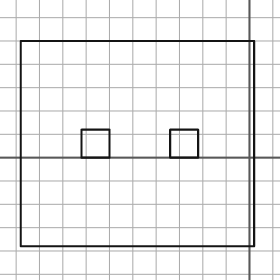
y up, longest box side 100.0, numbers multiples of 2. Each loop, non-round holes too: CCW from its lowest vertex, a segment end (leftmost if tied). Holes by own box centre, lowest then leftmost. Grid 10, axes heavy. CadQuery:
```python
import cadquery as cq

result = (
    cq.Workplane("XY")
    .moveTo(-98.0, -38.0)
    .lineTo(2.0, -38.0)
    .lineTo(2.0, 50.0)
    .lineTo(-98.0, 50.0)
    .close()
    .moveTo(-72.0, 0.0)
    .lineTo(-60.0, 0.0)
    .lineTo(-60.0, 12.0)
    .lineTo(-72.0, 12.0)
    .close()
    .moveTo(-34.0, 0.0)
    .lineTo(-22.0, 0.0)
    .lineTo(-22.0, 12.0)
    .lineTo(-34.0, 12.0)
    .close()
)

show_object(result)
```